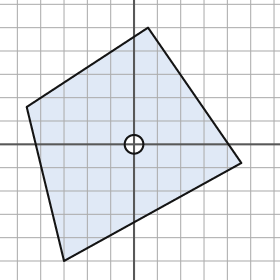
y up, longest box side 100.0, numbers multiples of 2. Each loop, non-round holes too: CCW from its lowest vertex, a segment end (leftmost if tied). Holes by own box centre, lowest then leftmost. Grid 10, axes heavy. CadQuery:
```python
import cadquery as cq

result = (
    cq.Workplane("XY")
    .moveTo(-30.0, -50.0)
    .lineTo(46.0, -8.0)
    .lineTo(6.0, 50.0)
    .lineTo(-46.0, 16.0)
    .close()
    .moveTo(0.0, 0.0)
    .circle(4.0)
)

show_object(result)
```